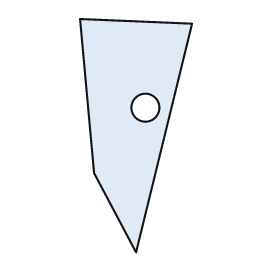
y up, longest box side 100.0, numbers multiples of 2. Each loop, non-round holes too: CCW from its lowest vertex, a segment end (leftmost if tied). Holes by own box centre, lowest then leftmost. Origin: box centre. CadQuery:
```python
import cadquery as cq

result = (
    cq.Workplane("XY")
    .moveTo(0.0, -50.0)
    .lineTo(24.0, 48.0)
    .lineTo(-24.0, 50.0)
    .lineTo(-18.0, -16.0)
    .close()
    .moveTo(4.0, 12.0)
    .circle(6.0)
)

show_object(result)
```